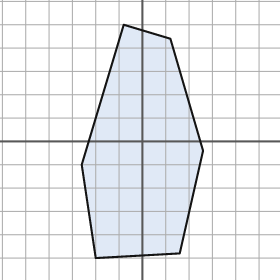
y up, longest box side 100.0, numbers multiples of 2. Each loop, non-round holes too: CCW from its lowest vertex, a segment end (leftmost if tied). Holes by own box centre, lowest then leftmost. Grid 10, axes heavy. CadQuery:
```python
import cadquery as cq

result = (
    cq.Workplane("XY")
    .moveTo(-20.0, -50.0)
    .lineTo(16.0, -48.0)
    .lineTo(26.0, -4.0)
    .lineTo(12.0, 44.0)
    .lineTo(-8.0, 50.0)
    .lineTo(-26.0, -10.0)
    .close()
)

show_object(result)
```